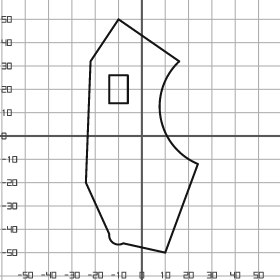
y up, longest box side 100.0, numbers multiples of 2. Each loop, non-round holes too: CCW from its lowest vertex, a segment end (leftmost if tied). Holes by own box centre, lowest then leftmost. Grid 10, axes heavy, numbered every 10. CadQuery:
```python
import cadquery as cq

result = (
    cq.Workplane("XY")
    .moveTo(10.0, -50.0)
    .lineTo(24.0, -12.0)
    .threePointArc((8.0, 8.0), (16.0, 32.0))
    .lineTo(-10.0, 50.0)
    .lineTo(-22.0, 32.0)
    .lineTo(-24.0, -20.0)
    .lineTo(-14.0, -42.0)
    .threePointArc((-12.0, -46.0), (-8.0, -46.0))
    .close()
    .moveTo(-14.0, 14.0)
    .lineTo(-6.0, 14.0)
    .lineTo(-6.0, 26.0)
    .lineTo(-14.0, 26.0)
    .close()
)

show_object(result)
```